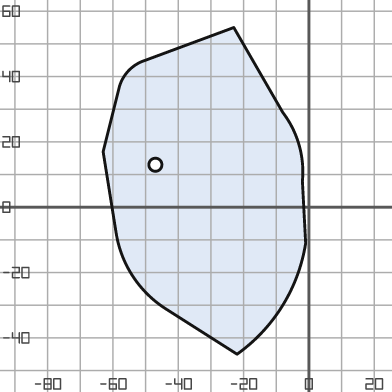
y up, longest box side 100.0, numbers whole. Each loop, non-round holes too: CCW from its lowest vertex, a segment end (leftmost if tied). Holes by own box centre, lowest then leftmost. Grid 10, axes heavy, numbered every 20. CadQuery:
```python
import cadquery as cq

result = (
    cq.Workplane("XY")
    .moveTo(-22.0, -45.0)
    .threePointArc((-8.0, -30.0), (-1.0, -11.0))
    .lineTo(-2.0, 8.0)
    .threePointArc((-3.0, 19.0), (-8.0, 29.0))
    .lineTo(-23.0, 55.0)
    .lineTo(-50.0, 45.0)
    .threePointArc((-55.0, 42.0), (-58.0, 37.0))
    .lineTo(-63.0, 17.0)
    .lineTo(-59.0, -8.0)
    .threePointArc((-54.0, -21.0), (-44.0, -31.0))
    .close()
    .moveTo(-47.0, 13.0)
    .circle(2.0)
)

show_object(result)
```